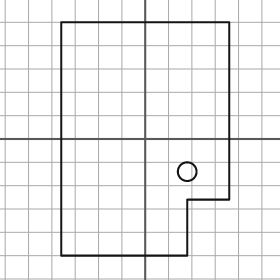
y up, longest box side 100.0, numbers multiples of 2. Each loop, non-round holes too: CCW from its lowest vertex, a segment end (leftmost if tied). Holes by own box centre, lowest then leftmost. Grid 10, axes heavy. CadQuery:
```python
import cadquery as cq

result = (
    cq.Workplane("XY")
    .moveTo(-36.0, -50.0)
    .lineTo(18.0, -50.0)
    .lineTo(18.0, -26.0)
    .lineTo(36.0, -26.0)
    .lineTo(36.0, 50.0)
    .lineTo(-36.0, 50.0)
    .close()
    .moveTo(18.0, -14.0)
    .circle(4.0)
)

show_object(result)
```